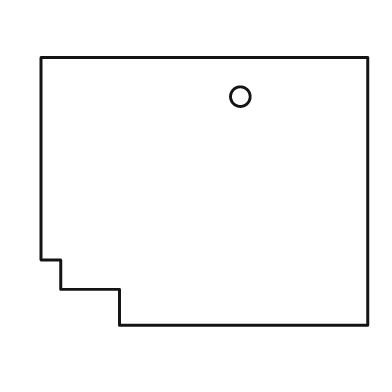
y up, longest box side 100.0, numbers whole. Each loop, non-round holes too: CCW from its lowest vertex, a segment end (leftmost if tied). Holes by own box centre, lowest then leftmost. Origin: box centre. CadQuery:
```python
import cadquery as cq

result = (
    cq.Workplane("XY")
    .moveTo(-26.0, -41.0)
    .lineTo(50.0, -41.0)
    .lineTo(50.0, 41.0)
    .lineTo(-50.0, 41.0)
    .lineTo(-50.0, -21.0)
    .lineTo(-44.0, -21.0)
    .lineTo(-44.0, -30.0)
    .lineTo(-26.0, -30.0)
    .close()
    .moveTo(11.0, 29.0)
    .circle(3.0)
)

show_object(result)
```